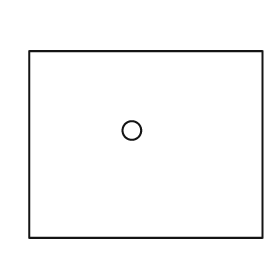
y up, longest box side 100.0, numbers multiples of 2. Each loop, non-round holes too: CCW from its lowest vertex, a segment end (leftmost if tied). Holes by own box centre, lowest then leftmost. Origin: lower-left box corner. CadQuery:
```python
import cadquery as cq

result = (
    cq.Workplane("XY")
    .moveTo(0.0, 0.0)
    .lineTo(100.0, 0.0)
    .lineTo(100.0, 80.0)
    .lineTo(0.0, 80.0)
    .close()
    .moveTo(44.0, 46.0)
    .circle(4.0)
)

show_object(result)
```